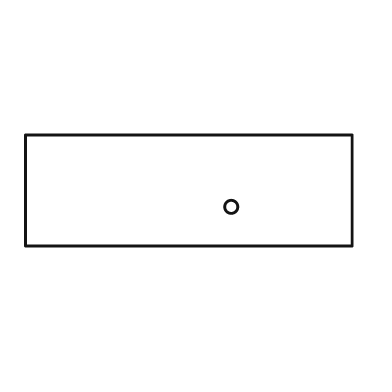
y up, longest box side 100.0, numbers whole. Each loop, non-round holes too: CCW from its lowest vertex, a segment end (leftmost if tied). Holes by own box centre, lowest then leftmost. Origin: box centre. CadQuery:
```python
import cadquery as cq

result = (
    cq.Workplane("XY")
    .moveTo(-50.0, -17.0)
    .lineTo(50.0, -17.0)
    .lineTo(50.0, 17.0)
    .lineTo(-50.0, 17.0)
    .close()
    .moveTo(13.0, -5.0)
    .circle(2.0)
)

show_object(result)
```